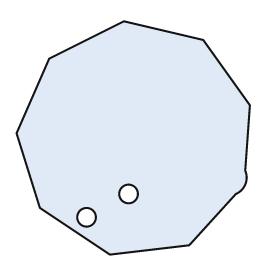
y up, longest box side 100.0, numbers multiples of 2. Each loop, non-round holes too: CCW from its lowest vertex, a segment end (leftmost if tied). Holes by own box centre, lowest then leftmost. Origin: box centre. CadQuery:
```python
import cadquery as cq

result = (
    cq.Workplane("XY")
    .moveTo(-10.0, -50.0)
    .lineTo(24.0, -46.0)
    .lineTo(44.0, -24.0)
    .threePointArc((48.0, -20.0), (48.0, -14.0))
    .lineTo(50.0, 14.0)
    .lineTo(30.0, 42.0)
    .lineTo(-4.0, 50.0)
    .lineTo(-36.0, 34.0)
    .lineTo(-50.0, 2.0)
    .lineTo(-40.0, -30.0)
    .close()
    .moveTo(-20.0, -34.0)
    .circle(4.0)
    .moveTo(-2.0, -24.0)
    .circle(4.0)
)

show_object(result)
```